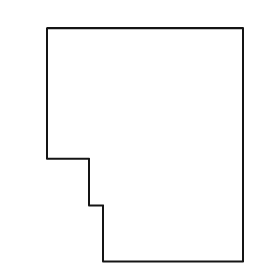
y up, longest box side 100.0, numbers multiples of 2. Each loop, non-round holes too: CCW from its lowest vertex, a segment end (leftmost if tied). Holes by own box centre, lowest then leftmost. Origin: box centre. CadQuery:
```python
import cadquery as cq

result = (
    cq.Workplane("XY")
    .moveTo(-18.0, -50.0)
    .lineTo(42.0, -50.0)
    .lineTo(42.0, 50.0)
    .lineTo(-42.0, 50.0)
    .lineTo(-42.0, -6.0)
    .lineTo(-24.0, -6.0)
    .lineTo(-24.0, -26.0)
    .lineTo(-18.0, -26.0)
    .close()
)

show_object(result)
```